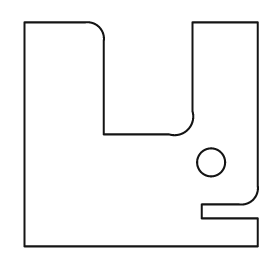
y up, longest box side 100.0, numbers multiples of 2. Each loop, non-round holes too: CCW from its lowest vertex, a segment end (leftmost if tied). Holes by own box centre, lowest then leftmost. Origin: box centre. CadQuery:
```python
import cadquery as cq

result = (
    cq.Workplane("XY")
    .moveTo(-50.0, -48.0)
    .lineTo(50.0, -48.0)
    .lineTo(50.0, -36.0)
    .lineTo(26.0, -36.0)
    .lineTo(26.0, -30.0)
    .lineTo(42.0, -30.0)
    .threePointArc((48.0, -28.0), (50.0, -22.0))
    .lineTo(50.0, 48.0)
    .lineTo(22.0, 48.0)
    .lineTo(22.0, 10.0)
    .threePointArc((20.0, 2.0), (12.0, 0.0))
    .lineTo(-16.0, 0.0)
    .lineTo(-16.0, 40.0)
    .threePointArc((-18.0, 46.0), (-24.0, 48.0))
    .lineTo(-50.0, 48.0)
    .close()
    .moveTo(30.0, -12.0)
    .circle(6.0)
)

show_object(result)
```